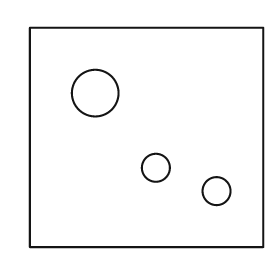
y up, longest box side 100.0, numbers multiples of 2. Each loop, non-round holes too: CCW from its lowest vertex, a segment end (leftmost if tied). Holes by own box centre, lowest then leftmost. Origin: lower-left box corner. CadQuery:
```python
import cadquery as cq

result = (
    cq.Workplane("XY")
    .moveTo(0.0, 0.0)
    .lineTo(100.0, 0.0)
    .lineTo(100.0, 94.0)
    .lineTo(0.0, 94.0)
    .close()
    .moveTo(80.0, 24.0)
    .circle(6.0)
    .moveTo(54.0, 34.0)
    .circle(6.0)
    .moveTo(28.0, 66.0)
    .circle(10.0)
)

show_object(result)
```